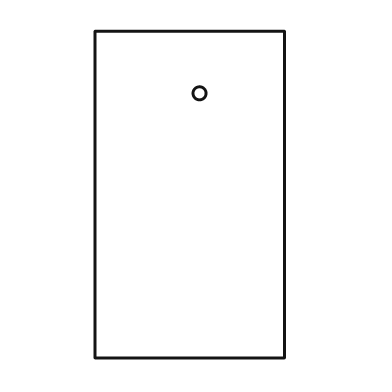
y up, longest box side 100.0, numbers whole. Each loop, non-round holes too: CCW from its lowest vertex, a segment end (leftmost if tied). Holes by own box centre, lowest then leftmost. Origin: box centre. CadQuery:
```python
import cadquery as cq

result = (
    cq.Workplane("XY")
    .moveTo(-29.0, -50.0)
    .lineTo(29.0, -50.0)
    .lineTo(29.0, 50.0)
    .lineTo(-29.0, 50.0)
    .close()
    .moveTo(3.0, 31.0)
    .circle(2.0)
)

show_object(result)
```